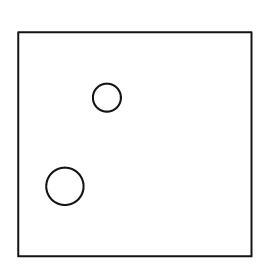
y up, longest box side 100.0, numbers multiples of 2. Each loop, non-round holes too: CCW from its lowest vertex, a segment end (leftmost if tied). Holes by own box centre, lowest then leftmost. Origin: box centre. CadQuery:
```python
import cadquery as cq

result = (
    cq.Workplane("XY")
    .moveTo(-50.0, -48.0)
    .lineTo(50.0, -48.0)
    .lineTo(50.0, 48.0)
    .lineTo(-50.0, 48.0)
    .close()
    .moveTo(-30.0, -18.0)
    .circle(8.0)
    .moveTo(-12.0, 20.0)
    .circle(6.0)
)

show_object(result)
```